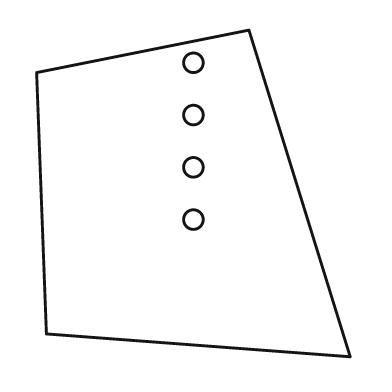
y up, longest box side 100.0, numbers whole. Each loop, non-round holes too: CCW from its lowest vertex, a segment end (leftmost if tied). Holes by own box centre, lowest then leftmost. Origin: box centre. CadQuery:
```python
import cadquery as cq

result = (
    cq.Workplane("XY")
    .moveTo(48.0, -50.0)
    .lineTo(17.0, 50.0)
    .lineTo(-48.0, 37.0)
    .lineTo(-45.0, -43.0)
    .close()
    .moveTo(0.0, -8.0)
    .circle(3.0)
    .moveTo(0.0, 8.0)
    .circle(3.0)
    .moveTo(0.0, 24.0)
    .circle(3.0)
    .moveTo(0.0, 40.0)
    .circle(3.0)
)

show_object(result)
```